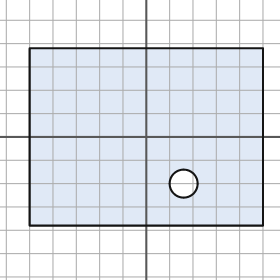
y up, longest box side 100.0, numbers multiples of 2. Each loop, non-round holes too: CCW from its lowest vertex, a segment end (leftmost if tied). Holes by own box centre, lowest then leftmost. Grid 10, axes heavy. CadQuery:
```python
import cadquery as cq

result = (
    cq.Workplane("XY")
    .moveTo(-50.0, -38.0)
    .lineTo(50.0, -38.0)
    .lineTo(50.0, 38.0)
    .lineTo(-50.0, 38.0)
    .close()
    .moveTo(16.0, -20.0)
    .circle(6.0)
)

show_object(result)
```